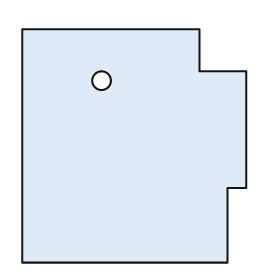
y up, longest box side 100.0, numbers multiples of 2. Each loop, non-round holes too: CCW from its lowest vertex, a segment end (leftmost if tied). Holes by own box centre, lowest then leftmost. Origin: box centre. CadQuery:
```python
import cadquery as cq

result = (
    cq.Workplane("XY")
    .moveTo(-48.0, -50.0)
    .lineTo(40.0, -50.0)
    .lineTo(40.0, -18.0)
    .lineTo(48.0, -18.0)
    .lineTo(48.0, 32.0)
    .lineTo(28.0, 32.0)
    .lineTo(28.0, 50.0)
    .lineTo(-48.0, 50.0)
    .close()
    .moveTo(-14.0, 28.0)
    .circle(4.0)
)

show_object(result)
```